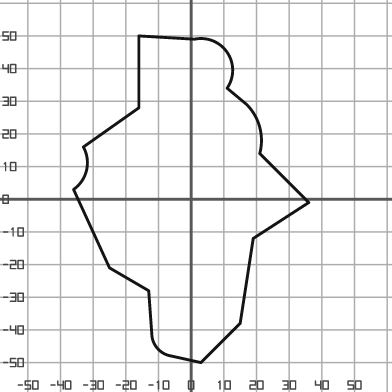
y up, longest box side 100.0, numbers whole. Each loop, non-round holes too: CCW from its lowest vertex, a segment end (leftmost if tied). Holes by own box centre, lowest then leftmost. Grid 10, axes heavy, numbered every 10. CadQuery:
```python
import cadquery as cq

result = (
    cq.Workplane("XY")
    .moveTo(3.0, -50.0)
    .lineTo(15.0, -38.0)
    .lineTo(19.0, -12.0)
    .lineTo(36.0, -1.0)
    .lineTo(21.0, 14.0)
    .threePointArc((21.0, 22.0), (17.0, 29.0))
    .lineTo(11.0, 34.0)
    .threePointArc((11.0, 45.0), (1.0, 49.0))
    .lineTo(-16.0, 50.0)
    .lineTo(-16.0, 28.0)
    .lineTo(-33.0, 16.0)
    .threePointArc((-32.0, 9.0), (-36.0, 3.0))
    .lineTo(-25.0, -21.0)
    .lineTo(-13.0, -28.0)
    .lineTo(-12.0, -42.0)
    .threePointArc((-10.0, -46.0), (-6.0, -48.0))
    .close()
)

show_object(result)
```